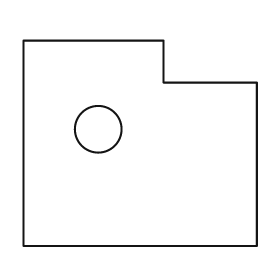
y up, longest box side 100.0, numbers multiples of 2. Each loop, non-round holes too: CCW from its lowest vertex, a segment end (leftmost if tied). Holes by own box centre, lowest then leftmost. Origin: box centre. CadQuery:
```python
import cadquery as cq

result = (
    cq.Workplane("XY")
    .moveTo(-50.0, -44.0)
    .lineTo(50.0, -44.0)
    .lineTo(50.0, 26.0)
    .lineTo(10.0, 26.0)
    .lineTo(10.0, 44.0)
    .lineTo(-50.0, 44.0)
    .close()
    .moveTo(-18.0, 6.0)
    .circle(10.0)
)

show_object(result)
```